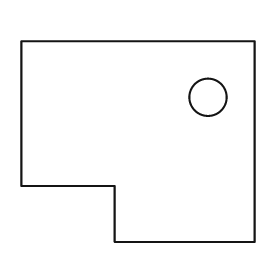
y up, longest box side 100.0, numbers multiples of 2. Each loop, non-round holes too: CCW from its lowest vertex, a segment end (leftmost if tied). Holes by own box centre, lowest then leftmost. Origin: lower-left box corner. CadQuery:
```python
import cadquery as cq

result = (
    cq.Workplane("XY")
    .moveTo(40.0, 0.0)
    .lineTo(100.0, 0.0)
    .lineTo(100.0, 86.0)
    .lineTo(0.0, 86.0)
    .lineTo(0.0, 24.0)
    .lineTo(40.0, 24.0)
    .close()
    .moveTo(80.0, 62.0)
    .circle(8.0)
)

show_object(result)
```